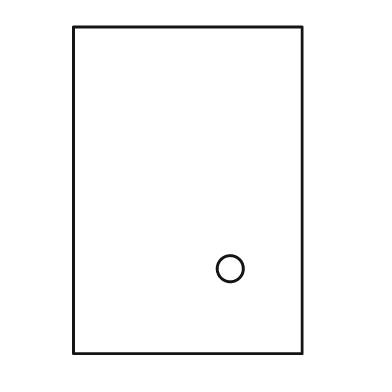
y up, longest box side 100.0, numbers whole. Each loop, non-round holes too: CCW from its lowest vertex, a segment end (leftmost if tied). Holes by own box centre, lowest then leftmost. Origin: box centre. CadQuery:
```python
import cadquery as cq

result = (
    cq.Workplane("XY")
    .moveTo(-35.0, -50.0)
    .lineTo(35.0, -50.0)
    .lineTo(35.0, 50.0)
    .lineTo(-35.0, 50.0)
    .close()
    .moveTo(13.0, -24.0)
    .circle(4.0)
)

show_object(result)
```